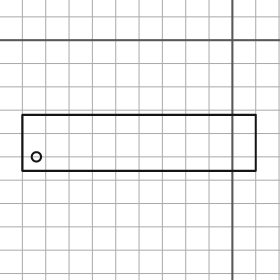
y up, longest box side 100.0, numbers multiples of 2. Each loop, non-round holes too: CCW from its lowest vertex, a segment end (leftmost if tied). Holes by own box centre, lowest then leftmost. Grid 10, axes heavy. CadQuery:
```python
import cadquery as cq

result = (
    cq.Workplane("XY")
    .moveTo(-90.0, -56.0)
    .lineTo(10.0, -56.0)
    .lineTo(10.0, -32.0)
    .lineTo(-90.0, -32.0)
    .close()
    .moveTo(-84.0, -50.0)
    .circle(2.0)
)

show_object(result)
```